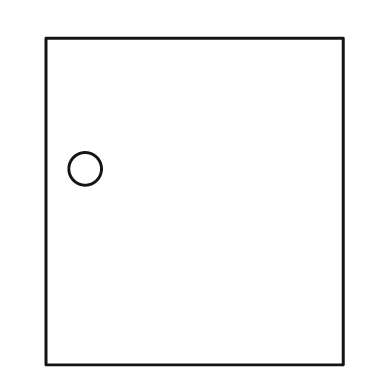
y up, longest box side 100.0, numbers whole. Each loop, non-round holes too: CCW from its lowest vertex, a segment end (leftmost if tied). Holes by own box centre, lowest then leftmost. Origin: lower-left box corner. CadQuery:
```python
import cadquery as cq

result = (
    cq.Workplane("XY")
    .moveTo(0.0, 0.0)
    .lineTo(91.0, 0.0)
    .lineTo(91.0, 100.0)
    .lineTo(0.0, 100.0)
    .close()
    .moveTo(12.0, 60.0)
    .circle(5.0)
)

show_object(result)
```